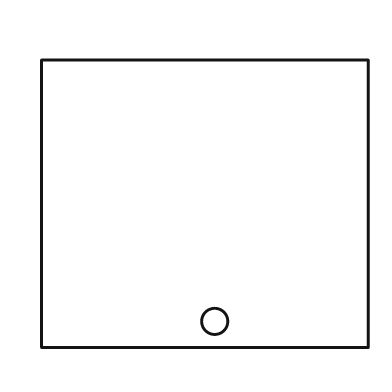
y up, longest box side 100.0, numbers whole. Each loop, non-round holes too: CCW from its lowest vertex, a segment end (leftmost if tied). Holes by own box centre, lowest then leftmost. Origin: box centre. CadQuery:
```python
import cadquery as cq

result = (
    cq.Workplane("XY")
    .moveTo(-50.0, -44.0)
    .lineTo(50.0, -44.0)
    .lineTo(50.0, 44.0)
    .lineTo(-50.0, 44.0)
    .close()
    .moveTo(3.0, -36.0)
    .circle(4.0)
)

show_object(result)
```